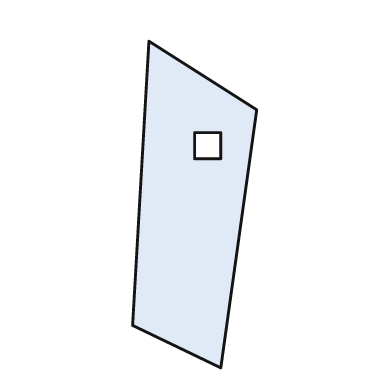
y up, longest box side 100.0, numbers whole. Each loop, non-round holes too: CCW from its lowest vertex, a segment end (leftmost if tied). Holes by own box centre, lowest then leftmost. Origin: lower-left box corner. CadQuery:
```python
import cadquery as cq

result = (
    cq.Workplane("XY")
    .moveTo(27.0, 0.0)
    .lineTo(38.0, 79.0)
    .lineTo(5.0, 100.0)
    .lineTo(0.0, 13.0)
    .close()
    .moveTo(19.0, 64.0)
    .lineTo(27.0, 64.0)
    .lineTo(27.0, 72.0)
    .lineTo(19.0, 72.0)
    .close()
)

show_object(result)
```